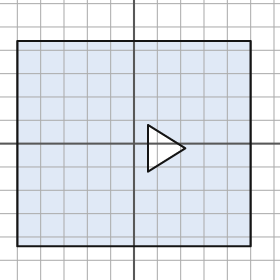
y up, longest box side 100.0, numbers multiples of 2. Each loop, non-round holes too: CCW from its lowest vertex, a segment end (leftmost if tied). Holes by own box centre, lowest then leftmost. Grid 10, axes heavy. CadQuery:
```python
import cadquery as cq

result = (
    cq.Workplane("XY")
    .moveTo(-50.0, -44.0)
    .lineTo(50.0, -44.0)
    .lineTo(50.0, 44.0)
    .lineTo(-50.0, 44.0)
    .close()
    .moveTo(6.0, -12.0)
    .lineTo(22.0, -2.0)
    .lineTo(6.0, 8.0)
    .close()
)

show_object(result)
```